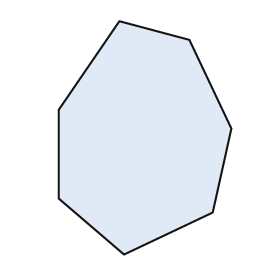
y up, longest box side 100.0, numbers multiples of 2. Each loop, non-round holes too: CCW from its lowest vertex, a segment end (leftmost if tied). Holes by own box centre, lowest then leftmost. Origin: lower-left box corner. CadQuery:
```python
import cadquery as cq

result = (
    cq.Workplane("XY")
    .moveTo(28.0, 0.0)
    .lineTo(66.0, 18.0)
    .lineTo(74.0, 54.0)
    .lineTo(56.0, 92.0)
    .lineTo(26.0, 100.0)
    .lineTo(0.0, 62.0)
    .lineTo(0.0, 24.0)
    .close()
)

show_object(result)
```